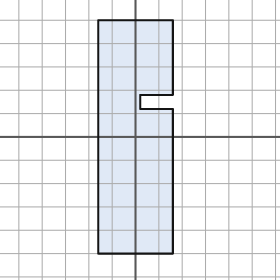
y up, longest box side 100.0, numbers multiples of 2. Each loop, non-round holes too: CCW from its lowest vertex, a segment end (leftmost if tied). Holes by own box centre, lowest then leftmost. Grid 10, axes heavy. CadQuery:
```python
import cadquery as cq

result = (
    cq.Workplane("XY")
    .moveTo(-16.0, -50.0)
    .lineTo(16.0, -50.0)
    .lineTo(16.0, 12.0)
    .lineTo(2.0, 12.0)
    .lineTo(2.0, 18.0)
    .lineTo(16.0, 18.0)
    .lineTo(16.0, 50.0)
    .lineTo(-16.0, 50.0)
    .close()
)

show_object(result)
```